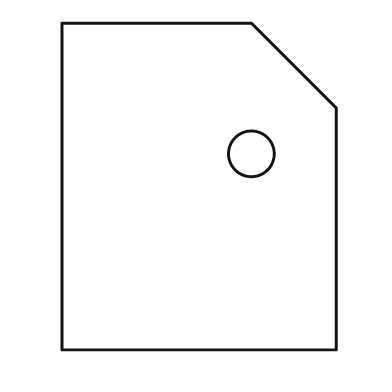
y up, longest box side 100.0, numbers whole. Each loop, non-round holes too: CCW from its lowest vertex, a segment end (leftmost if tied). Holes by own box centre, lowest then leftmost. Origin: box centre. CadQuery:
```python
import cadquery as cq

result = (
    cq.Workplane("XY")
    .moveTo(-42.0, -50.0)
    .lineTo(42.0, -50.0)
    .lineTo(42.0, 24.0)
    .lineTo(16.0, 50.0)
    .lineTo(-42.0, 50.0)
    .close()
    .moveTo(16.0, 10.0)
    .circle(7.0)
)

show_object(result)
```